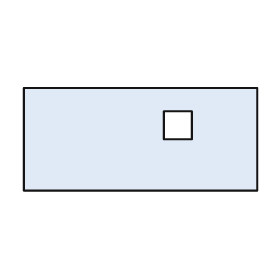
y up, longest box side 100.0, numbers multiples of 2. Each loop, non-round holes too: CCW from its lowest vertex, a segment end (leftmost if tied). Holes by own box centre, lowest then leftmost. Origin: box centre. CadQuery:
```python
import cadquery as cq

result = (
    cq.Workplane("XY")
    .moveTo(-50.0, -22.0)
    .lineTo(50.0, -22.0)
    .lineTo(50.0, 22.0)
    .lineTo(-50.0, 22.0)
    .close()
    .moveTo(10.0, 0.0)
    .lineTo(22.0, 0.0)
    .lineTo(22.0, 12.0)
    .lineTo(10.0, 12.0)
    .close()
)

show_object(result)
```